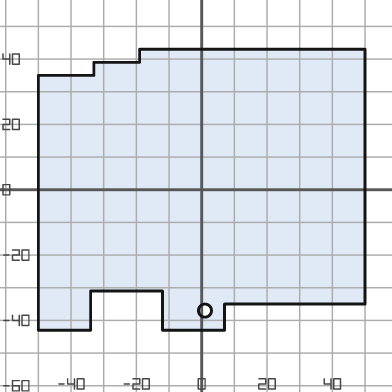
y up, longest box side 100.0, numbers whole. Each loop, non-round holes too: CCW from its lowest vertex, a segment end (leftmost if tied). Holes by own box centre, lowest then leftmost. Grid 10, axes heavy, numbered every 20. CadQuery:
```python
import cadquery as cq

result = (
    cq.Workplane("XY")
    .moveTo(-50.0, -43.0)
    .lineTo(-34.0, -43.0)
    .lineTo(-34.0, -31.0)
    .lineTo(-12.0, -31.0)
    .lineTo(-12.0, -43.0)
    .lineTo(7.0, -43.0)
    .lineTo(7.0, -35.0)
    .lineTo(50.0, -35.0)
    .lineTo(50.0, 43.0)
    .lineTo(-19.0, 43.0)
    .lineTo(-19.0, 39.0)
    .lineTo(-33.0, 39.0)
    .lineTo(-33.0, 35.0)
    .lineTo(-50.0, 35.0)
    .close()
    .moveTo(1.0, -37.0)
    .circle(2.0)
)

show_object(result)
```